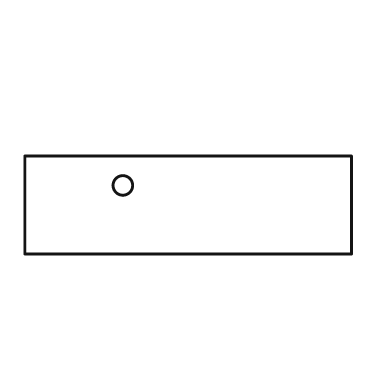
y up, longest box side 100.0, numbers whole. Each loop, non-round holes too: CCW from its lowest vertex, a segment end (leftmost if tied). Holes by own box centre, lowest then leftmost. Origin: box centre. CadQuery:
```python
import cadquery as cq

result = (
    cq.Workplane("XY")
    .moveTo(-50.0, -15.0)
    .lineTo(50.0, -15.0)
    .lineTo(50.0, 15.0)
    .lineTo(-50.0, 15.0)
    .close()
    .moveTo(-20.0, 6.0)
    .circle(3.0)
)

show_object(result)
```